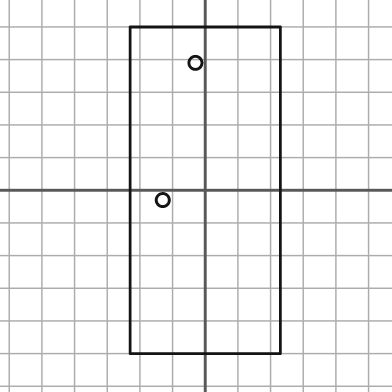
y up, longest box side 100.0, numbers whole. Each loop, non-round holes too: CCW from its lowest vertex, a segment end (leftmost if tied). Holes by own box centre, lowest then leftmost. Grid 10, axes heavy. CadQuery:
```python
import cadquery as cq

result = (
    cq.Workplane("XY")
    .moveTo(-23.0, -50.0)
    .lineTo(23.0, -50.0)
    .lineTo(23.0, 50.0)
    .lineTo(-23.0, 50.0)
    .close()
    .moveTo(-13.0, -3.0)
    .circle(2.0)
    .moveTo(-3.0, 39.0)
    .circle(2.0)
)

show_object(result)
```